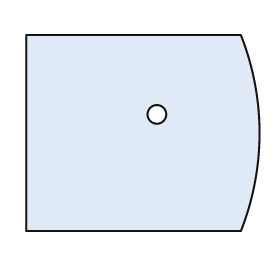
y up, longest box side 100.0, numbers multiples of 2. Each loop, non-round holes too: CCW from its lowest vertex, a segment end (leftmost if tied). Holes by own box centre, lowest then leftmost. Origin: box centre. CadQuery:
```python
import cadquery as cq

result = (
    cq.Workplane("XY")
    .moveTo(-50.0, -42.0)
    .lineTo(42.0, -42.0)
    .threePointArc((50.0, 0.0), (42.0, 42.0))
    .lineTo(-50.0, 42.0)
    .close()
    .moveTo(6.0, 8.0)
    .circle(4.0)
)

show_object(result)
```